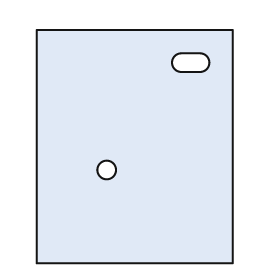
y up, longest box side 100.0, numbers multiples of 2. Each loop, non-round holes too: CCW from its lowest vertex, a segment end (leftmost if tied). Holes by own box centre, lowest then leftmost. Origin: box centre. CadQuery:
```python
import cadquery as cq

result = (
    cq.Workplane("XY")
    .moveTo(-42.0, -50.0)
    .lineTo(42.0, -50.0)
    .lineTo(42.0, 50.0)
    .lineTo(-42.0, 50.0)
    .close()
    .moveTo(-12.0, -10.0)
    .circle(4.0)
    .moveTo(20.0, 32.0)
    .lineTo(28.0, 32.0)
    .threePointArc((32.0, 36.0), (28.0, 40.0))
    .lineTo(20.0, 40.0)
    .threePointArc((16.0, 36.0), (20.0, 32.0))
    .close()
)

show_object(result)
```